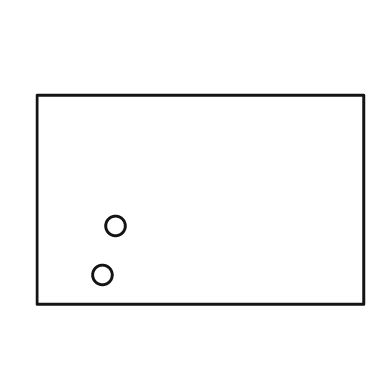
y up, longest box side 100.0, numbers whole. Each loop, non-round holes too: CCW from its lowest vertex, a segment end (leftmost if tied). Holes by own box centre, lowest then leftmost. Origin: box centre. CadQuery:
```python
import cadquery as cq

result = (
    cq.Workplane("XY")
    .moveTo(-50.0, -32.0)
    .lineTo(50.0, -32.0)
    .lineTo(50.0, 32.0)
    .lineTo(-50.0, 32.0)
    .close()
    .moveTo(-30.0, -23.0)
    .circle(3.0)
    .moveTo(-26.0, -8.0)
    .circle(3.0)
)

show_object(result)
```